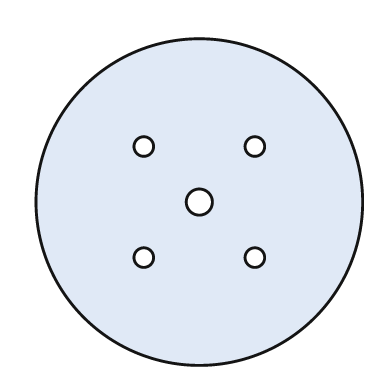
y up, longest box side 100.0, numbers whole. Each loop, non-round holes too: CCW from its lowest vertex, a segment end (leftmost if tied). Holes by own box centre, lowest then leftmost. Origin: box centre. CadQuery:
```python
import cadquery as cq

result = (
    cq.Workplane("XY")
    .moveTo(0.0, 0.0)
    .circle(50.0)
    .moveTo(-17.0, -17.0)
    .circle(3.0)
    .moveTo(17.0, -17.0)
    .circle(3.0)
    .moveTo(0.0, 0.0)
    .circle(4.0)
    .moveTo(-17.0, 17.0)
    .circle(3.0)
    .moveTo(17.0, 17.0)
    .circle(3.0)
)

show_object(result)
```